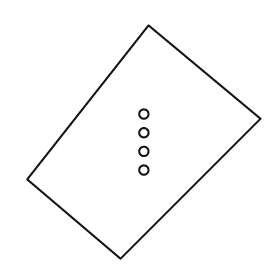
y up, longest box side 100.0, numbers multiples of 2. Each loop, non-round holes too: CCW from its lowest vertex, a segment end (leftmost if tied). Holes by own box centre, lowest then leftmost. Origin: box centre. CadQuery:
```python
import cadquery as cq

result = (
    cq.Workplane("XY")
    .moveTo(-10.0, -50.0)
    .lineTo(50.0, 10.0)
    .lineTo(2.0, 50.0)
    .lineTo(-50.0, -16.0)
    .close()
    .moveTo(0.0, -12.0)
    .circle(2.0)
    .moveTo(0.0, -4.0)
    .circle(2.0)
    .moveTo(0.0, 4.0)
    .circle(2.0)
    .moveTo(0.0, 12.0)
    .circle(2.0)
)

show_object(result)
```